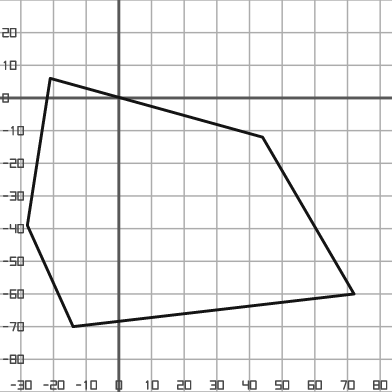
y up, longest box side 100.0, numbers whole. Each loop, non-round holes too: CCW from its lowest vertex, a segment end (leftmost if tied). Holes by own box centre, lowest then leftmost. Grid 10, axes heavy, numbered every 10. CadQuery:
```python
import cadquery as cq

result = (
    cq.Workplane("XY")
    .moveTo(-14.0, -70.0)
    .lineTo(72.0, -60.0)
    .lineTo(44.0, -12.0)
    .lineTo(-21.0, 6.0)
    .lineTo(-28.0, -39.0)
    .close()
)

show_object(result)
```